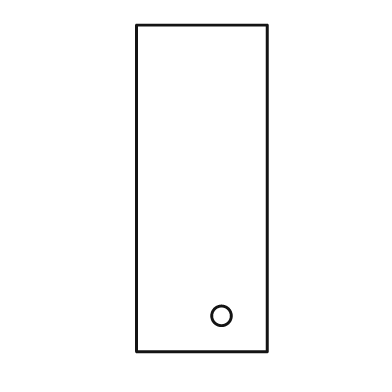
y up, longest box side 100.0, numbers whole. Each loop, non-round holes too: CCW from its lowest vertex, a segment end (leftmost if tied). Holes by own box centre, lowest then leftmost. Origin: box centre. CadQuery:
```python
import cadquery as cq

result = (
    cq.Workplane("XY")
    .moveTo(-20.0, -50.0)
    .lineTo(20.0, -50.0)
    .lineTo(20.0, 50.0)
    .lineTo(-20.0, 50.0)
    .close()
    .moveTo(6.0, -39.0)
    .circle(3.0)
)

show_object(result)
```